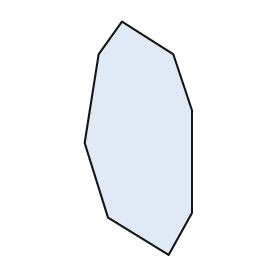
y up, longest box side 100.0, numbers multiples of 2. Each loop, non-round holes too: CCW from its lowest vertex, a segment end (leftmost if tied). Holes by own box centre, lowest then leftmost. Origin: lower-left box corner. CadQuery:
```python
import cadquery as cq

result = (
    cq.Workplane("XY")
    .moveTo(36.0, 0.0)
    .lineTo(46.0, 18.0)
    .lineTo(46.0, 62.0)
    .lineTo(38.0, 86.0)
    .lineTo(16.0, 100.0)
    .lineTo(6.0, 86.0)
    .lineTo(0.0, 48.0)
    .lineTo(10.0, 16.0)
    .close()
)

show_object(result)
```